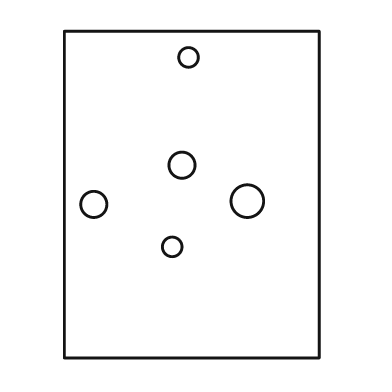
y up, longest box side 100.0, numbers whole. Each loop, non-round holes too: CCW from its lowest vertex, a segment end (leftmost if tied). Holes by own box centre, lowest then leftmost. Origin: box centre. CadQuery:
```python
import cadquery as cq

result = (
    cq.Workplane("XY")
    .moveTo(-39.0, -50.0)
    .lineTo(39.0, -50.0)
    .lineTo(39.0, 50.0)
    .lineTo(-39.0, 50.0)
    .close()
    .moveTo(-6.0, -16.0)
    .circle(3.0)
    .moveTo(-30.0, -3.0)
    .circle(4.0)
    .moveTo(17.0, -2.0)
    .circle(5.0)
    .moveTo(-3.0, 9.0)
    .circle(4.0)
    .moveTo(-1.0, 42.0)
    .circle(3.0)
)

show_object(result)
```